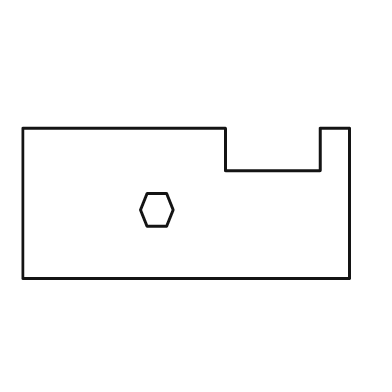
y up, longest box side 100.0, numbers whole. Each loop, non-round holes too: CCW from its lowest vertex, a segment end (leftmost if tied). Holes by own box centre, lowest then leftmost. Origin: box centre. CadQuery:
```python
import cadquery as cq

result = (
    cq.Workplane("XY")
    .moveTo(-50.0, -23.0)
    .lineTo(50.0, -23.0)
    .lineTo(50.0, 23.0)
    .lineTo(41.0, 23.0)
    .lineTo(41.0, 10.0)
    .lineTo(12.0, 10.0)
    .lineTo(12.0, 23.0)
    .lineTo(-50.0, 23.0)
    .close()
    .moveTo(-12.0, -7.0)
    .lineTo(-6.0, -7.0)
    .lineTo(-4.0, -2.0)
    .lineTo(-6.0, 3.0)
    .lineTo(-12.0, 3.0)
    .lineTo(-14.0, -2.0)
    .close()
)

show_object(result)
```